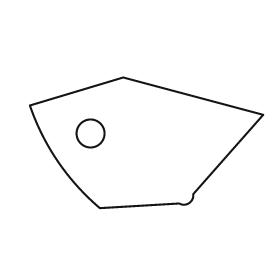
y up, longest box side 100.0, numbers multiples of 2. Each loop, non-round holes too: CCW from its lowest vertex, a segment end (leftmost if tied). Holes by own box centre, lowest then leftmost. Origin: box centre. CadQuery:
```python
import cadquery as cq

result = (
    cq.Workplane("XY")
    .moveTo(-20.0, -28.0)
    .lineTo(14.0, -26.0)
    .threePointArc((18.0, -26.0), (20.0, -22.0))
    .lineTo(50.0, 12.0)
    .lineTo(-10.0, 28.0)
    .lineTo(-50.0, 16.0)
    .threePointArc((-38.0, -8.0), (-20.0, -28.0))
    .close()
    .moveTo(-24.0, 4.0)
    .circle(6.0)
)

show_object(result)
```